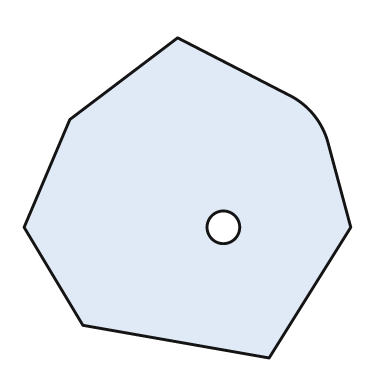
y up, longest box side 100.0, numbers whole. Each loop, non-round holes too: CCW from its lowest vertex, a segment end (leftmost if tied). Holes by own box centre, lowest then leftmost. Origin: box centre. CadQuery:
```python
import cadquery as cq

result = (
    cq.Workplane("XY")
    .moveTo(25.0, -49.0)
    .lineTo(50.0, -9.0)
    .lineTo(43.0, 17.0)
    .threePointArc((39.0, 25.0), (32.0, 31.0))
    .lineTo(-3.0, 49.0)
    .lineTo(-36.0, 24.0)
    .lineTo(-50.0, -9.0)
    .lineTo(-32.0, -39.0)
    .close()
    .moveTo(11.0, -9.0)
    .circle(5.0)
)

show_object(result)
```